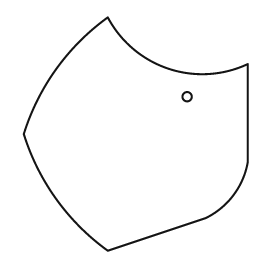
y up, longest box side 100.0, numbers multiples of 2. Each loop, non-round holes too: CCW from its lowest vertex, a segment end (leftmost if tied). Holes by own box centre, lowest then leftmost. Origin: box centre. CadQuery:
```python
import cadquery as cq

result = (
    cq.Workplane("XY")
    .moveTo(-12.0, -50.0)
    .lineTo(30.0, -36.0)
    .threePointArc((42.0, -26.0), (48.0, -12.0))
    .lineTo(48.0, 30.0)
    .threePointArc((14.0, 28.0), (-12.0, 50.0))
    .threePointArc((-34.0, 28.0), (-48.0, 0.0))
    .threePointArc((-34.0, -28.0), (-12.0, -50.0))
    .close()
    .moveTo(22.0, 16.0)
    .circle(2.0)
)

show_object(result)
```